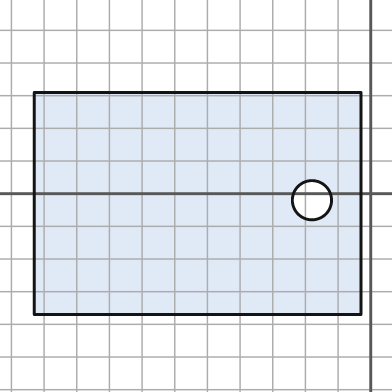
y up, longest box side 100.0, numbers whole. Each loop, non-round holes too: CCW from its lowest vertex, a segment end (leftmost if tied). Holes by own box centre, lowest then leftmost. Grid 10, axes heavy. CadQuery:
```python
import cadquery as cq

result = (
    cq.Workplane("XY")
    .moveTo(-103.0, -37.0)
    .lineTo(-3.0, -37.0)
    .lineTo(-3.0, 31.0)
    .lineTo(-103.0, 31.0)
    .close()
    .moveTo(-18.0, -2.0)
    .circle(6.0)
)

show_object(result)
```